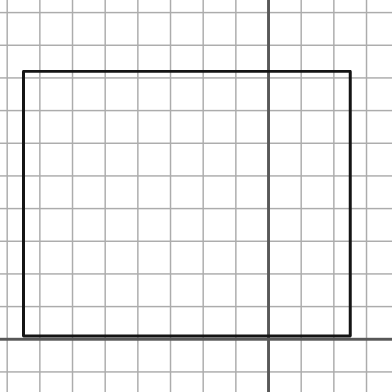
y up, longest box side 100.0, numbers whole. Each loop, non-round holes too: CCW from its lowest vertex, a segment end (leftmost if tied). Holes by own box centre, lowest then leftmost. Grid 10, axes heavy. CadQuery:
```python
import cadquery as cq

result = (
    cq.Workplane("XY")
    .moveTo(-75.0, 1.0)
    .lineTo(25.0, 1.0)
    .lineTo(25.0, 82.0)
    .lineTo(-75.0, 82.0)
    .close()
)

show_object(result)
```